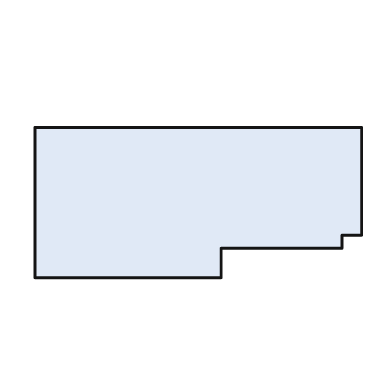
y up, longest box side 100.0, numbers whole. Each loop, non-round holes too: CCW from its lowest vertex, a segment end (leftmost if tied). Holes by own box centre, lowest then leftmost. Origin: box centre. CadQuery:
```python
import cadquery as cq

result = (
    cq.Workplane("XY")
    .moveTo(-50.0, -23.0)
    .lineTo(7.0, -23.0)
    .lineTo(7.0, -14.0)
    .lineTo(44.0, -14.0)
    .lineTo(44.0, -10.0)
    .lineTo(50.0, -10.0)
    .lineTo(50.0, 23.0)
    .lineTo(-50.0, 23.0)
    .close()
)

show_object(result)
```